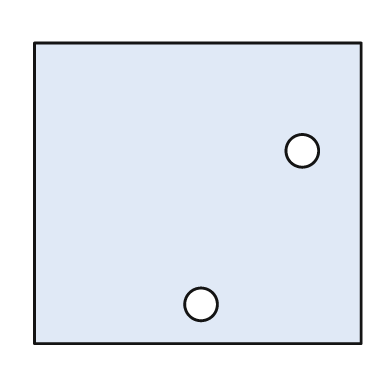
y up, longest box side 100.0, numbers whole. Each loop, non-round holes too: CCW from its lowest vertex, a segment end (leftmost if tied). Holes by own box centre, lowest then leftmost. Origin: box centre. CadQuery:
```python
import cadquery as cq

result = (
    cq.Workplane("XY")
    .moveTo(-50.0, -46.0)
    .lineTo(50.0, -46.0)
    .lineTo(50.0, 46.0)
    .lineTo(-50.0, 46.0)
    .close()
    .moveTo(1.0, -34.0)
    .circle(5.0)
    .moveTo(32.0, 13.0)
    .circle(5.0)
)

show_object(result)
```